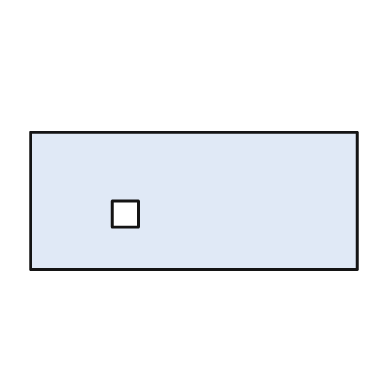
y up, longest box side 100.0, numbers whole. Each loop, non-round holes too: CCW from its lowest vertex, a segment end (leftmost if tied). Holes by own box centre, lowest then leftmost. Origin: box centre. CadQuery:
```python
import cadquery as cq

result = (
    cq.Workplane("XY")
    .moveTo(-50.0, -21.0)
    .lineTo(50.0, -21.0)
    .lineTo(50.0, 21.0)
    .lineTo(-50.0, 21.0)
    .close()
    .moveTo(-25.0, -8.0)
    .lineTo(-17.0, -8.0)
    .lineTo(-17.0, 0.0)
    .lineTo(-25.0, 0.0)
    .close()
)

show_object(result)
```